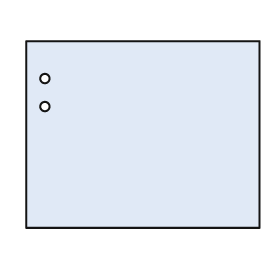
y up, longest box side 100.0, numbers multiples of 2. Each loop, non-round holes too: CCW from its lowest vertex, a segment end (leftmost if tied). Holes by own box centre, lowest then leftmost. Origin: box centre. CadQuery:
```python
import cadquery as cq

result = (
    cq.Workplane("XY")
    .moveTo(-50.0, -40.0)
    .lineTo(50.0, -40.0)
    .lineTo(50.0, 40.0)
    .lineTo(-50.0, 40.0)
    .close()
    .moveTo(-42.0, 12.0)
    .circle(2.0)
    .moveTo(-42.0, 24.0)
    .circle(2.0)
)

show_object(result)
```